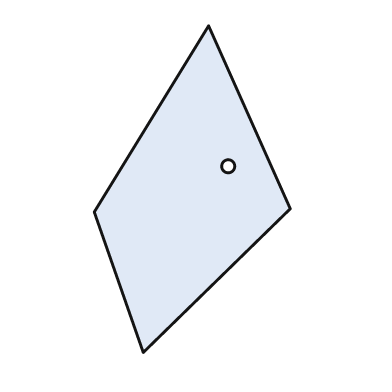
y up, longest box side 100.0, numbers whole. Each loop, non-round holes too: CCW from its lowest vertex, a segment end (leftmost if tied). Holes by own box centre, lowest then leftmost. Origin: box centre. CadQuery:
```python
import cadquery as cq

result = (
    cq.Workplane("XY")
    .moveTo(-15.0, -50.0)
    .lineTo(30.0, -6.0)
    .lineTo(5.0, 50.0)
    .lineTo(-30.0, -7.0)
    .close()
    .moveTo(11.0, 7.0)
    .circle(2.0)
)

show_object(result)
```